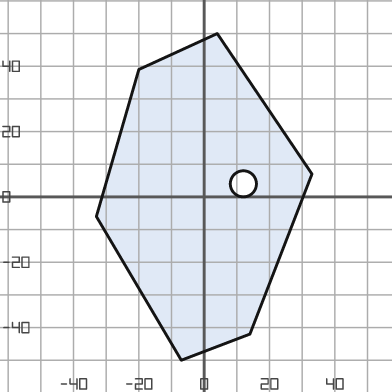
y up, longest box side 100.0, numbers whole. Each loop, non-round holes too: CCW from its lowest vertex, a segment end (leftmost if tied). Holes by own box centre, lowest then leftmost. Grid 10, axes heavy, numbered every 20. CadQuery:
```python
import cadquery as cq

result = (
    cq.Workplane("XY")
    .moveTo(-7.0, -50.0)
    .lineTo(14.0, -42.0)
    .lineTo(33.0, 7.0)
    .lineTo(4.0, 50.0)
    .lineTo(-20.0, 39.0)
    .lineTo(-33.0, -6.0)
    .close()
    .moveTo(12.0, 4.0)
    .circle(4.0)
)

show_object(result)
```